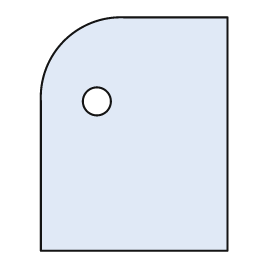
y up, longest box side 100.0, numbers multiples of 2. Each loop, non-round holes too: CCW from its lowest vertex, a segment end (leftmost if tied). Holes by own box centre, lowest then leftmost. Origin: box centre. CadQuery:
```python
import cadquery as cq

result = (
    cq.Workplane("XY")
    .moveTo(-40.0, -50.0)
    .lineTo(40.0, -50.0)
    .lineTo(40.0, 50.0)
    .lineTo(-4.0, 50.0)
    .threePointArc((-30.0, 40.0), (-40.0, 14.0))
    .close()
    .moveTo(-16.0, 14.0)
    .circle(6.0)
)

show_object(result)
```